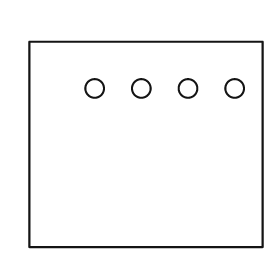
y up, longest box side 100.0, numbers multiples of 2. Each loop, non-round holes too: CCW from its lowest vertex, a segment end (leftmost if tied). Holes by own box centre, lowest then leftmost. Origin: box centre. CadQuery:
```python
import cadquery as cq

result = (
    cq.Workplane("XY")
    .moveTo(-50.0, -44.0)
    .lineTo(50.0, -44.0)
    .lineTo(50.0, 44.0)
    .lineTo(-50.0, 44.0)
    .close()
    .moveTo(-22.0, 24.0)
    .circle(4.0)
    .moveTo(-2.0, 24.0)
    .circle(4.0)
    .moveTo(18.0, 24.0)
    .circle(4.0)
    .moveTo(38.0, 24.0)
    .circle(4.0)
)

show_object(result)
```